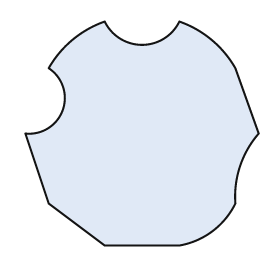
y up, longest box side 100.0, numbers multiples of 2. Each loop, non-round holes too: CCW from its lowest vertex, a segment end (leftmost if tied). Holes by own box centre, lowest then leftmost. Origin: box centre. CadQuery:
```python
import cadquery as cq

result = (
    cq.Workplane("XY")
    .moveTo(-16.0, -48.0)
    .lineTo(16.0, -48.0)
    .threePointArc((30.0, -42.0), (40.0, -30.0))
    .threePointArc((42.0, -14.0), (50.0, 0.0))
    .lineTo(40.0, 28.0)
    .threePointArc((30.0, 40.0), (16.0, 48.0))
    .threePointArc((0.0, 38.0), (-16.0, 48.0))
    .threePointArc((-30.0, 40.0), (-40.0, 28.0))
    .threePointArc((-34.0, 10.0), (-50.0, 0.0))
    .lineTo(-40.0, -30.0)
    .close()
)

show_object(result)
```